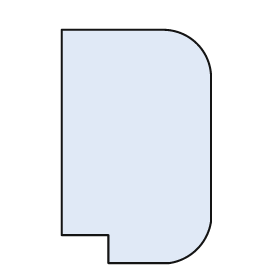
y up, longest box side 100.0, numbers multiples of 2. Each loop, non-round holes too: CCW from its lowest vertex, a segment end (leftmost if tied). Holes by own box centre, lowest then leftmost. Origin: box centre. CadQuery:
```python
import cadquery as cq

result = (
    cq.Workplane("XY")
    .moveTo(-12.0, -50.0)
    .lineTo(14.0, -50.0)
    .threePointArc((26.0, -44.0), (32.0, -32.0))
    .lineTo(32.0, 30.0)
    .threePointArc((26.0, 44.0), (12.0, 50.0))
    .lineTo(-32.0, 50.0)
    .lineTo(-32.0, -38.0)
    .lineTo(-12.0, -38.0)
    .close()
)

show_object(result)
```